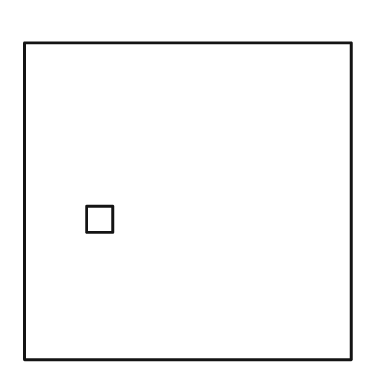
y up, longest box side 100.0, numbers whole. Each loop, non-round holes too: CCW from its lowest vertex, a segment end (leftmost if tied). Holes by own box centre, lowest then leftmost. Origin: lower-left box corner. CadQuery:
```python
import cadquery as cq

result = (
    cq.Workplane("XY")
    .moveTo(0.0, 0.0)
    .lineTo(100.0, 0.0)
    .lineTo(100.0, 97.0)
    .lineTo(0.0, 97.0)
    .close()
    .moveTo(19.0, 39.0)
    .lineTo(27.0, 39.0)
    .lineTo(27.0, 47.0)
    .lineTo(19.0, 47.0)
    .close()
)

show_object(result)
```